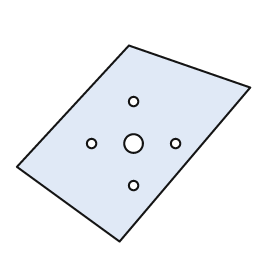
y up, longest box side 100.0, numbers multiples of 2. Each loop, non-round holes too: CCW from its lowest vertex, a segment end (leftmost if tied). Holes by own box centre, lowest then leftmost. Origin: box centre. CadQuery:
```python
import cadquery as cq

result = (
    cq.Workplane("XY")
    .moveTo(-6.0, -42.0)
    .lineTo(50.0, 24.0)
    .lineTo(-2.0, 42.0)
    .lineTo(-50.0, -10.0)
    .close()
    .moveTo(0.0, -18.0)
    .circle(2.0)
    .moveTo(-18.0, 0.0)
    .circle(2.0)
    .moveTo(0.0, 0.0)
    .circle(4.0)
    .moveTo(18.0, 0.0)
    .circle(2.0)
    .moveTo(0.0, 18.0)
    .circle(2.0)
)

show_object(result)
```